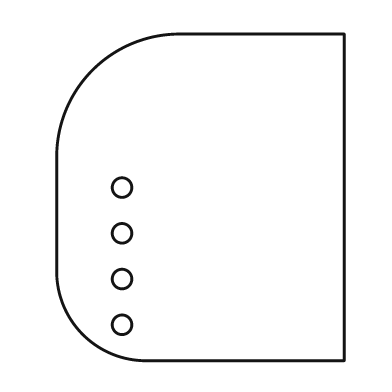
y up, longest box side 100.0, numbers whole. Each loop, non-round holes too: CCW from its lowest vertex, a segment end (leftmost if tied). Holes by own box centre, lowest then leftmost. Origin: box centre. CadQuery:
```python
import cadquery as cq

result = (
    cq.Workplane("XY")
    .moveTo(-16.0, -50.0)
    .lineTo(44.0, -50.0)
    .lineTo(44.0, 50.0)
    .lineTo(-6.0, 50.0)
    .threePointArc((-33.0, 39.0), (-44.0, 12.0))
    .lineTo(-44.0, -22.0)
    .threePointArc((-36.0, -42.0), (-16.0, -50.0))
    .close()
    .moveTo(-24.0, -39.0)
    .circle(3.0)
    .moveTo(-24.0, -25.0)
    .circle(3.0)
    .moveTo(-24.0, -11.0)
    .circle(3.0)
    .moveTo(-24.0, 3.0)
    .circle(3.0)
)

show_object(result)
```